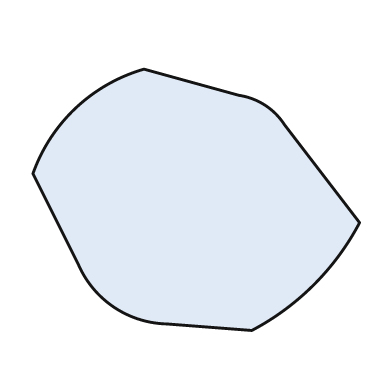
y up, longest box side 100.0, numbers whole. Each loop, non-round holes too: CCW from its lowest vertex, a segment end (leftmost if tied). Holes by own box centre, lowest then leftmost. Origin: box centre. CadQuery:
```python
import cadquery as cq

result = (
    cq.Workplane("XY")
    .moveTo(17.0, -40.0)
    .threePointArc((36.0, -26.0), (50.0, -7.0))
    .lineTo(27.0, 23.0)
    .threePointArc((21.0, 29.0), (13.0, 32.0))
    .lineTo(-16.0, 40.0)
    .threePointArc((-37.0, 28.0), (-50.0, 8.0))
    .lineTo(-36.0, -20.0)
    .threePointArc((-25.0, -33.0), (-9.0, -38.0))
    .close()
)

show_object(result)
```